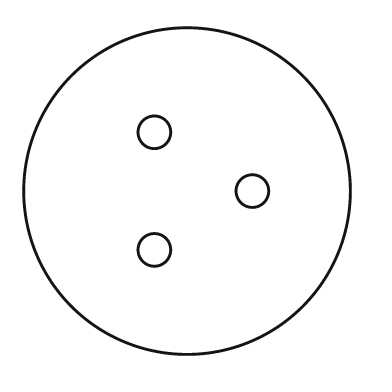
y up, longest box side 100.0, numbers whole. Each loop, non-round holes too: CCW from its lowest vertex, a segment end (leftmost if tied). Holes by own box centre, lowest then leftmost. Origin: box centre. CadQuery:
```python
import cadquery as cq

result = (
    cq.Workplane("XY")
    .moveTo(0.0, 0.0)
    .circle(50.0)
    .moveTo(-10.0, -18.0)
    .circle(5.0)
    .moveTo(20.0, 0.0)
    .circle(5.0)
    .moveTo(-10.0, 18.0)
    .circle(5.0)
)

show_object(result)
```